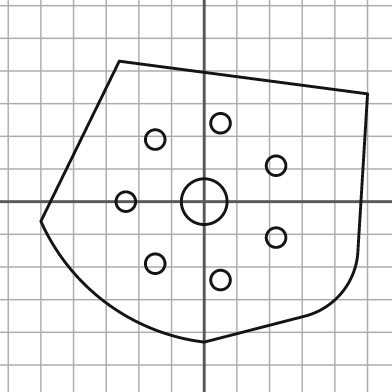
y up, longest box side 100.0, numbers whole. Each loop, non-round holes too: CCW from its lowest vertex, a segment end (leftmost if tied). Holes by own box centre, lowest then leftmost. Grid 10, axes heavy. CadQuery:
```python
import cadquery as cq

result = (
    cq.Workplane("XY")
    .moveTo(0.0, -43.0)
    .lineTo(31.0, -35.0)
    .threePointArc((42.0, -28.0), (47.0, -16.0))
    .lineTo(50.0, 33.0)
    .lineTo(-26.0, 43.0)
    .lineTo(-50.0, -6.0)
    .threePointArc((-30.0, -31.0), (0.0, -43.0))
    .close()
    .moveTo(5.0, -24.0)
    .circle(3.0)
    .moveTo(-15.0, -19.0)
    .circle(3.0)
    .moveTo(22.0, -11.0)
    .circle(3.0)
    .moveTo(-24.0, 0.0)
    .circle(3.0)
    .moveTo(0.0, 0.0)
    .circle(7.0)
    .moveTo(22.0, 11.0)
    .circle(3.0)
    .moveTo(-15.0, 19.0)
    .circle(3.0)
    .moveTo(5.0, 24.0)
    .circle(3.0)
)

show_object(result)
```